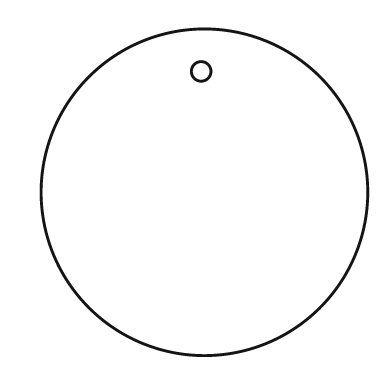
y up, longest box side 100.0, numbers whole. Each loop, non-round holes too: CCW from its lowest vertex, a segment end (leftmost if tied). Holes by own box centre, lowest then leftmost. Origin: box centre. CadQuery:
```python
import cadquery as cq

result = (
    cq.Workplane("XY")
    .moveTo(0.0, 0.0)
    .circle(50.0)
    .moveTo(-1.0, 37.0)
    .circle(3.0)
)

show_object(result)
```